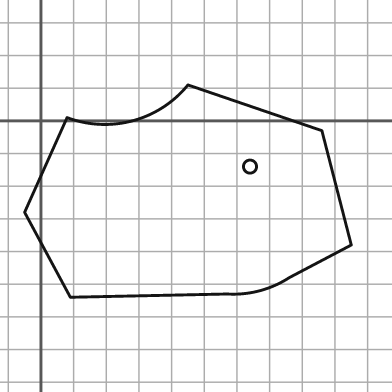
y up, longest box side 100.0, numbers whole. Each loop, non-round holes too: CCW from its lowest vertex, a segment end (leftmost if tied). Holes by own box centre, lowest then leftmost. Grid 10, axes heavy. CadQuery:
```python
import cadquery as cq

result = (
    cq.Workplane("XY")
    .moveTo(9.0, -54.0)
    .lineTo(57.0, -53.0)
    .threePointArc((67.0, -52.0), (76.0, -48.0))
    .lineTo(95.0, -38.0)
    .lineTo(86.0, -3.0)
    .lineTo(45.0, 11.0)
    .threePointArc((28.0, 0.0), (8.0, 1.0))
    .lineTo(-5.0, -28.0)
    .close()
    .moveTo(64.0, -14.0)
    .circle(2.0)
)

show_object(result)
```